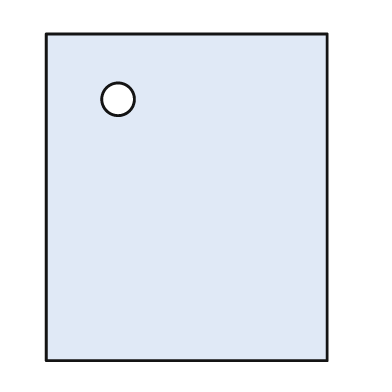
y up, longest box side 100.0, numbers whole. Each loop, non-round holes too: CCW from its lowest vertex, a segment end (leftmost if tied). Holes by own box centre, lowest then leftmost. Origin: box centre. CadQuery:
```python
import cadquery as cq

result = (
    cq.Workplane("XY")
    .moveTo(-43.0, -50.0)
    .lineTo(43.0, -50.0)
    .lineTo(43.0, 50.0)
    .lineTo(-43.0, 50.0)
    .close()
    .moveTo(-21.0, 30.0)
    .circle(5.0)
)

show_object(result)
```